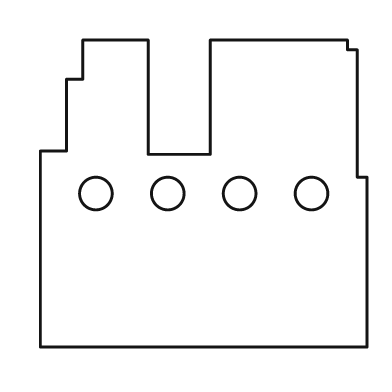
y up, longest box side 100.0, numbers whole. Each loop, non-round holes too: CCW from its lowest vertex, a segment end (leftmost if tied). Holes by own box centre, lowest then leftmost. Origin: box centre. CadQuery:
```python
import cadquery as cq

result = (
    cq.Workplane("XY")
    .moveTo(-50.0, -47.0)
    .lineTo(50.0, -47.0)
    .lineTo(50.0, 5.0)
    .lineTo(47.0, 5.0)
    .lineTo(47.0, 44.0)
    .lineTo(44.0, 44.0)
    .lineTo(44.0, 47.0)
    .lineTo(2.0, 47.0)
    .lineTo(2.0, 12.0)
    .lineTo(-17.0, 12.0)
    .lineTo(-17.0, 47.0)
    .lineTo(-37.0, 47.0)
    .lineTo(-37.0, 35.0)
    .lineTo(-42.0, 35.0)
    .lineTo(-42.0, 13.0)
    .lineTo(-50.0, 13.0)
    .close()
    .moveTo(-33.0, 0.0)
    .circle(5.0)
    .moveTo(-11.0, 0.0)
    .circle(5.0)
    .moveTo(11.0, 0.0)
    .circle(5.0)
    .moveTo(33.0, 0.0)
    .circle(5.0)
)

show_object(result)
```